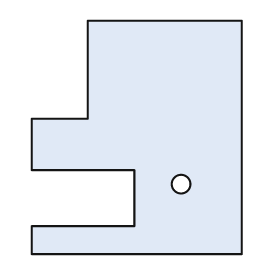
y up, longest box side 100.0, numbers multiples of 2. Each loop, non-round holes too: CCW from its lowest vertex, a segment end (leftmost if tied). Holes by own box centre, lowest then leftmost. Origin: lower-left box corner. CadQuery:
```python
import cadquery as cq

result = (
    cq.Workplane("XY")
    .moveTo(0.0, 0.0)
    .lineTo(90.0, 0.0)
    .lineTo(90.0, 100.0)
    .lineTo(24.0, 100.0)
    .lineTo(24.0, 58.0)
    .lineTo(0.0, 58.0)
    .lineTo(0.0, 36.0)
    .lineTo(44.0, 36.0)
    .lineTo(44.0, 12.0)
    .lineTo(0.0, 12.0)
    .close()
    .moveTo(64.0, 30.0)
    .circle(4.0)
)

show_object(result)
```